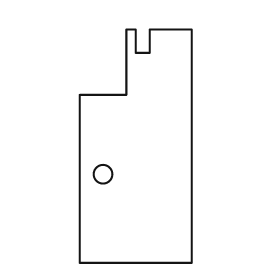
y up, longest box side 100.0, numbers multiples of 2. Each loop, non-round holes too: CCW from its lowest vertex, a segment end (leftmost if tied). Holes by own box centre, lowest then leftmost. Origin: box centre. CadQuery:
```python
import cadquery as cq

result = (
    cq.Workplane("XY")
    .moveTo(-24.0, -50.0)
    .lineTo(24.0, -50.0)
    .lineTo(24.0, 50.0)
    .lineTo(6.0, 50.0)
    .lineTo(6.0, 40.0)
    .lineTo(0.0, 40.0)
    .lineTo(0.0, 50.0)
    .lineTo(-4.0, 50.0)
    .lineTo(-4.0, 22.0)
    .lineTo(-24.0, 22.0)
    .close()
    .moveTo(-14.0, -12.0)
    .circle(4.0)
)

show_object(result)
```